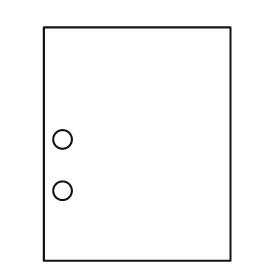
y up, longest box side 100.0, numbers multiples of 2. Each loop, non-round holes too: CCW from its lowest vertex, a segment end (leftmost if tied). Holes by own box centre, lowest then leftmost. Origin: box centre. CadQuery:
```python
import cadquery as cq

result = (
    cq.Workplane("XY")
    .moveTo(-40.0, -50.0)
    .lineTo(40.0, -50.0)
    .lineTo(40.0, 50.0)
    .lineTo(-40.0, 50.0)
    .close()
    .moveTo(-32.0, -20.0)
    .circle(4.0)
    .moveTo(-32.0, 2.0)
    .circle(4.0)
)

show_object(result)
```